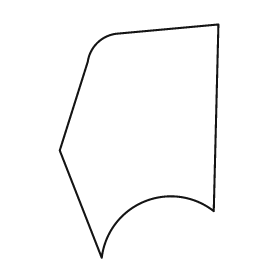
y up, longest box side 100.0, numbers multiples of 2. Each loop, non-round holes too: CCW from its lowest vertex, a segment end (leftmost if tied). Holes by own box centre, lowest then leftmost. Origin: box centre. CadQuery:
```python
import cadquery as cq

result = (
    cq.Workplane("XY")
    .moveTo(-16.0, -50.0)
    .threePointArc((2.0, -26.0), (32.0, -30.0))
    .lineTo(34.0, 50.0)
    .lineTo(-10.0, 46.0)
    .threePointArc((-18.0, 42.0), (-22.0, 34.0))
    .lineTo(-34.0, -4.0)
    .close()
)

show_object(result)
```